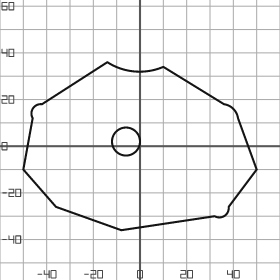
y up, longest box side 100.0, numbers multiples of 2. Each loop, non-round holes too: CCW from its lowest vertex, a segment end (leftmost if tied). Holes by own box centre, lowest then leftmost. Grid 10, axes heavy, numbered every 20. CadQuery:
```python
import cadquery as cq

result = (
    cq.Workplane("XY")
    .moveTo(-8.0, -36.0)
    .lineTo(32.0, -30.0)
    .threePointArc((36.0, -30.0), (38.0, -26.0))
    .lineTo(50.0, -10.0)
    .lineTo(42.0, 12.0)
    .threePointArc((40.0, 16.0), (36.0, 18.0))
    .lineTo(10.0, 34.0)
    .threePointArc((-2.0, 32.0), (-14.0, 36.0))
    .lineTo(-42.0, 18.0)
    .threePointArc((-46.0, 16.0), (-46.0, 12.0))
    .lineTo(-50.0, -10.0)
    .lineTo(-36.0, -26.0)
    .close()
    .moveTo(-6.0, 2.0)
    .circle(6.0)
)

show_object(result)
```